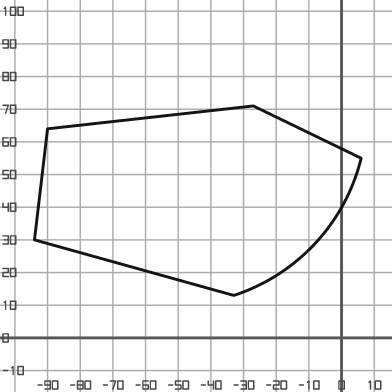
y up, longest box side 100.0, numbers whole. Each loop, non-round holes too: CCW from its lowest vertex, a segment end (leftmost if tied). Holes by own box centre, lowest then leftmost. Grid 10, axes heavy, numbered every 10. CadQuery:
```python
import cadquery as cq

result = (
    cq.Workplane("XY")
    .moveTo(-33.0, 13.0)
    .threePointArc((-8.0, 29.0), (6.0, 55.0))
    .lineTo(-27.0, 71.0)
    .lineTo(-90.0, 64.0)
    .lineTo(-94.0, 30.0)
    .close()
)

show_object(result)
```